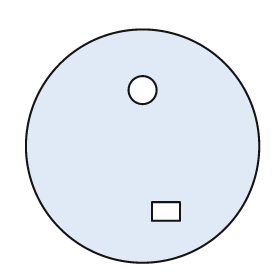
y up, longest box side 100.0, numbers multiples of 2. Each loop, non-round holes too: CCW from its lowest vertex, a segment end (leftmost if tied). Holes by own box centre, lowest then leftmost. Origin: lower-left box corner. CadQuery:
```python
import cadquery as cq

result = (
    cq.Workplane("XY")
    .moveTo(50.0, 50.0)
    .circle(50.0)
    .moveTo(54.0, 18.0)
    .lineTo(66.0, 18.0)
    .lineTo(66.0, 26.0)
    .lineTo(54.0, 26.0)
    .close()
    .moveTo(50.0, 74.0)
    .circle(6.0)
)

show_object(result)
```